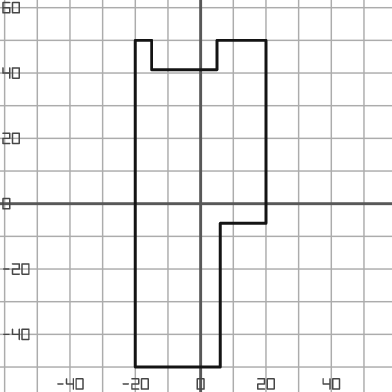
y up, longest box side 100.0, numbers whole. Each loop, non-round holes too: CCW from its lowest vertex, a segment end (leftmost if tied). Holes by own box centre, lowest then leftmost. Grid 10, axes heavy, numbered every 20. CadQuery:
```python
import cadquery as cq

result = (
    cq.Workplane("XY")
    .moveTo(-20.0, -50.0)
    .lineTo(6.0, -50.0)
    .lineTo(6.0, -6.0)
    .lineTo(20.0, -6.0)
    .lineTo(20.0, 50.0)
    .lineTo(5.0, 50.0)
    .lineTo(5.0, 41.0)
    .lineTo(-15.0, 41.0)
    .lineTo(-15.0, 50.0)
    .lineTo(-20.0, 50.0)
    .close()
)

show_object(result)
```